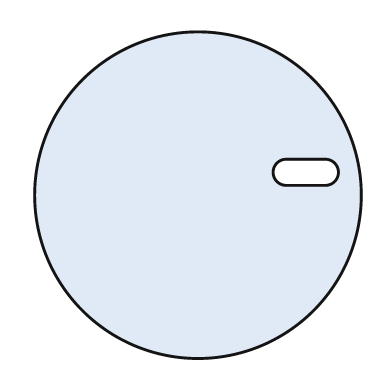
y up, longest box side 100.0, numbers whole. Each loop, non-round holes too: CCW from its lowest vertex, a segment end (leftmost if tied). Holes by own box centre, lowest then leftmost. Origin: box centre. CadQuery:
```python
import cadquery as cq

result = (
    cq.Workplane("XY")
    .moveTo(0.0, 0.0)
    .circle(50.0)
    .moveTo(27.0, 3.0)
    .lineTo(39.0, 3.0)
    .threePointArc((43.0, 7.0), (39.0, 11.0))
    .lineTo(27.0, 11.0)
    .threePointArc((23.0, 7.0), (27.0, 3.0))
    .close()
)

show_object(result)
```